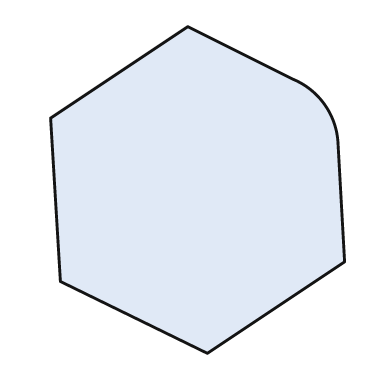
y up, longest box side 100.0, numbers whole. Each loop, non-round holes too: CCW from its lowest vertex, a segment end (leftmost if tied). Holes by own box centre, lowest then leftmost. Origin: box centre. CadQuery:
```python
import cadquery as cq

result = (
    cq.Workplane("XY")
    .moveTo(3.0, -50.0)
    .lineTo(45.0, -22.0)
    .lineTo(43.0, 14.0)
    .threePointArc((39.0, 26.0), (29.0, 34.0))
    .lineTo(-3.0, 50.0)
    .lineTo(-45.0, 22.0)
    .lineTo(-42.0, -28.0)
    .close()
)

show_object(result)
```